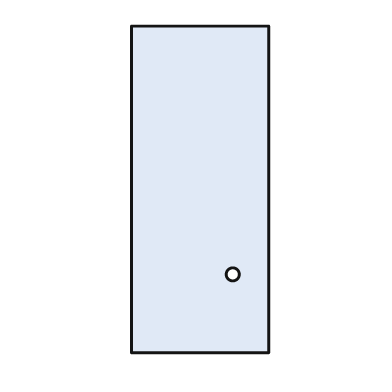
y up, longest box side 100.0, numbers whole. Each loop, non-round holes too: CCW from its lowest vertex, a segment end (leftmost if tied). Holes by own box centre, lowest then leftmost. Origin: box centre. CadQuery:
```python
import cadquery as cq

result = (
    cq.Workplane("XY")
    .moveTo(-21.0, -50.0)
    .lineTo(21.0, -50.0)
    .lineTo(21.0, 50.0)
    .lineTo(-21.0, 50.0)
    .close()
    .moveTo(10.0, -26.0)
    .circle(2.0)
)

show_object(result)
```